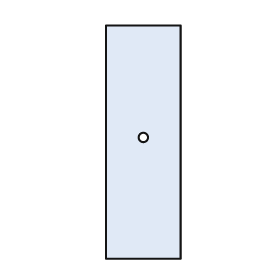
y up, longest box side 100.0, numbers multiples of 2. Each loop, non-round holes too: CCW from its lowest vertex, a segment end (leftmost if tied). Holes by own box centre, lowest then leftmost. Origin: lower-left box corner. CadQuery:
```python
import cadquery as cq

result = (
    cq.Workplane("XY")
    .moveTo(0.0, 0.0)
    .lineTo(32.0, 0.0)
    .lineTo(32.0, 100.0)
    .lineTo(0.0, 100.0)
    .close()
    .moveTo(16.0, 52.0)
    .circle(2.0)
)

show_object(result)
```